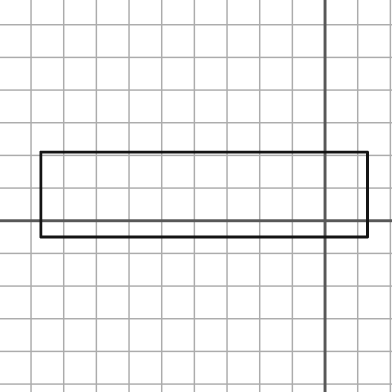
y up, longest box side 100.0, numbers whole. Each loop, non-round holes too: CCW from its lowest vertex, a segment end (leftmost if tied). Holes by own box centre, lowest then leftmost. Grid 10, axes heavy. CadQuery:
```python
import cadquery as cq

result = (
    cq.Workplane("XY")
    .moveTo(-87.0, -5.0)
    .lineTo(13.0, -5.0)
    .lineTo(13.0, 21.0)
    .lineTo(-87.0, 21.0)
    .close()
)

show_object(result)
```